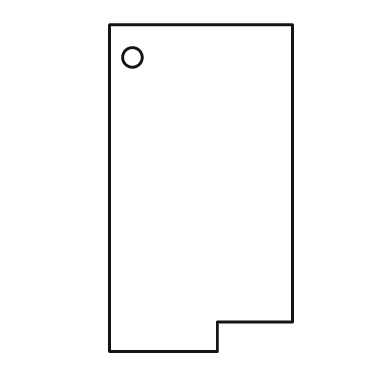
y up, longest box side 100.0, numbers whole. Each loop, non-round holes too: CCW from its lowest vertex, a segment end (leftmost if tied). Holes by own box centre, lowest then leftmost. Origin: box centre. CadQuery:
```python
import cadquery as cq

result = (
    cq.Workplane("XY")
    .moveTo(-28.0, -50.0)
    .lineTo(5.0, -50.0)
    .lineTo(5.0, -41.0)
    .lineTo(28.0, -41.0)
    .lineTo(28.0, 50.0)
    .lineTo(-28.0, 50.0)
    .close()
    .moveTo(-21.0, 40.0)
    .circle(3.0)
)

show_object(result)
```